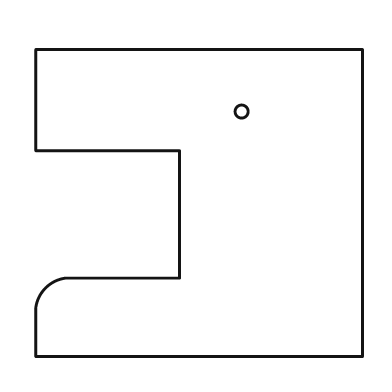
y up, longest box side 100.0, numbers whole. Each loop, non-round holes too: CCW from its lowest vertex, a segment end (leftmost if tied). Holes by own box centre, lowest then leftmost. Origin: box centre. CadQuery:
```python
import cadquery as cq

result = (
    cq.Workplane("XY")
    .moveTo(-50.0, -47.0)
    .lineTo(50.0, -47.0)
    .lineTo(50.0, 47.0)
    .lineTo(-50.0, 47.0)
    .lineTo(-50.0, 16.0)
    .lineTo(-6.0, 16.0)
    .lineTo(-6.0, -23.0)
    .lineTo(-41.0, -23.0)
    .threePointArc((-47.0, -26.0), (-50.0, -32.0))
    .close()
    .moveTo(13.0, 28.0)
    .circle(2.0)
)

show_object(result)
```